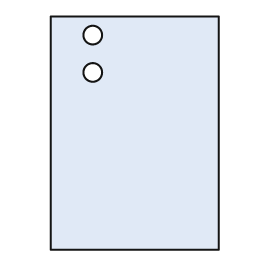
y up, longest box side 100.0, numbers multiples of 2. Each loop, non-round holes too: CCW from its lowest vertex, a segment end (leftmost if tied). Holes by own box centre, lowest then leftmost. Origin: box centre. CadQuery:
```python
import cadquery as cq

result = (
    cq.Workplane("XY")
    .moveTo(-36.0, -50.0)
    .lineTo(36.0, -50.0)
    .lineTo(36.0, 50.0)
    .lineTo(-36.0, 50.0)
    .close()
    .moveTo(-18.0, 26.0)
    .circle(4.0)
    .moveTo(-18.0, 42.0)
    .circle(4.0)
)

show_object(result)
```